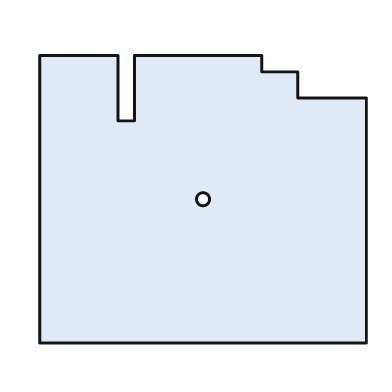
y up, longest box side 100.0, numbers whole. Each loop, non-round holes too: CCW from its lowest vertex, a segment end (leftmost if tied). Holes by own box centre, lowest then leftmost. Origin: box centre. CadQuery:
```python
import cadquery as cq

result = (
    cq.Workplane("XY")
    .moveTo(-50.0, -44.0)
    .lineTo(50.0, -44.0)
    .lineTo(50.0, 31.0)
    .lineTo(29.0, 31.0)
    .lineTo(29.0, 39.0)
    .lineTo(18.0, 39.0)
    .lineTo(18.0, 44.0)
    .lineTo(-21.0, 44.0)
    .lineTo(-21.0, 24.0)
    .lineTo(-26.0, 24.0)
    .lineTo(-26.0, 44.0)
    .lineTo(-50.0, 44.0)
    .close()
    .moveTo(0.0, 0.0)
    .circle(2.0)
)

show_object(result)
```